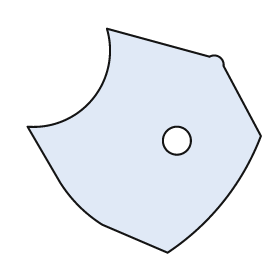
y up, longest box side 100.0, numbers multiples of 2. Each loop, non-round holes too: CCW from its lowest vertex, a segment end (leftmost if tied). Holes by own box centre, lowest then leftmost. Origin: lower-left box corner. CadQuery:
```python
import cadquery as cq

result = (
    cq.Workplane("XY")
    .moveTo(60.0, 0.0)
    .threePointArc((84.0, 22.0), (100.0, 50.0))
    .lineTo(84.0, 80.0)
    .threePointArc((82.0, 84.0), (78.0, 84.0))
    .lineTo(34.0, 96.0)
    .threePointArc((28.0, 66.0), (0.0, 54.0))
    .lineTo(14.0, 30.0)
    .threePointArc((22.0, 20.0), (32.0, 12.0))
    .close()
    .moveTo(64.0, 48.0)
    .circle(6.0)
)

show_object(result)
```